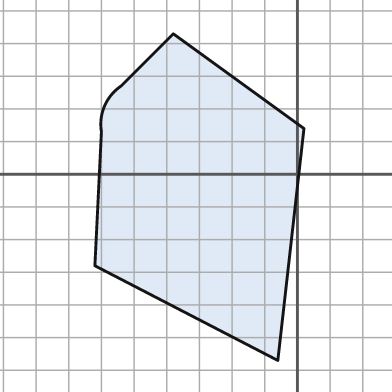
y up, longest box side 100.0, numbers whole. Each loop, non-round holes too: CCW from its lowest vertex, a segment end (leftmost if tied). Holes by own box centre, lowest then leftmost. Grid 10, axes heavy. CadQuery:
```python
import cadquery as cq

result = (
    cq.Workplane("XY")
    .moveTo(-6.0, -57.0)
    .lineTo(2.0, 14.0)
    .lineTo(-38.0, 43.0)
    .lineTo(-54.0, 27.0)
    .threePointArc((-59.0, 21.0), (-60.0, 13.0))
    .lineTo(-62.0, -28.0)
    .close()
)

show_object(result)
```